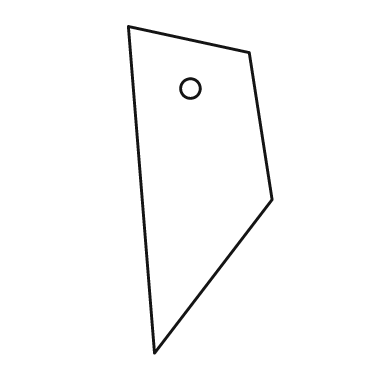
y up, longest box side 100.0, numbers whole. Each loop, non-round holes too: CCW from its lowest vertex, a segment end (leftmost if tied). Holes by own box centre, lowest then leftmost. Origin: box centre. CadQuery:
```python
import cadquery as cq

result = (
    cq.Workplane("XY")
    .moveTo(-14.0, -50.0)
    .lineTo(22.0, -3.0)
    .lineTo(15.0, 42.0)
    .lineTo(-22.0, 50.0)
    .close()
    .moveTo(-3.0, 31.0)
    .circle(3.0)
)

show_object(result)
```